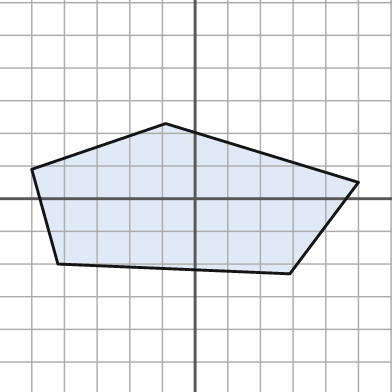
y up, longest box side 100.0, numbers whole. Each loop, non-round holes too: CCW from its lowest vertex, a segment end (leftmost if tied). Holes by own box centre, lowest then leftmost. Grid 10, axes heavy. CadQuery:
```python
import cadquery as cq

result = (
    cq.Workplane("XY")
    .moveTo(29.0, -23.0)
    .lineTo(50.0, 5.0)
    .lineTo(-9.0, 23.0)
    .lineTo(-50.0, 9.0)
    .lineTo(-42.0, -20.0)
    .close()
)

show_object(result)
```